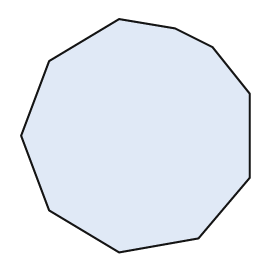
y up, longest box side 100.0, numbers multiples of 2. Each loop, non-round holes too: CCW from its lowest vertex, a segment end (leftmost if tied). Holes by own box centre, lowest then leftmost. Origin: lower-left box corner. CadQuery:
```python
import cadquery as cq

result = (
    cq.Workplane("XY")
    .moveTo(42.0, 0.0)
    .lineTo(76.0, 6.0)
    .lineTo(98.0, 32.0)
    .lineTo(98.0, 68.0)
    .lineTo(82.0, 88.0)
    .lineTo(66.0, 96.0)
    .lineTo(42.0, 100.0)
    .lineTo(12.0, 82.0)
    .lineTo(0.0, 50.0)
    .lineTo(12.0, 18.0)
    .close()
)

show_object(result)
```